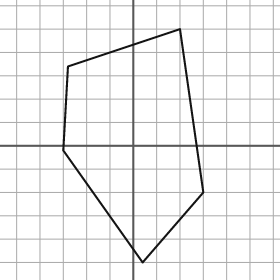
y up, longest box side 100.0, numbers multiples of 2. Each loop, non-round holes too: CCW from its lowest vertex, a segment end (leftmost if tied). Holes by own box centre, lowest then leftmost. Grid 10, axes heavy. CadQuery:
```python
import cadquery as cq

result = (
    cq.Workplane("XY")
    .moveTo(4.0, -50.0)
    .lineTo(30.0, -20.0)
    .lineTo(20.0, 50.0)
    .lineTo(-28.0, 34.0)
    .lineTo(-30.0, -2.0)
    .close()
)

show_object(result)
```